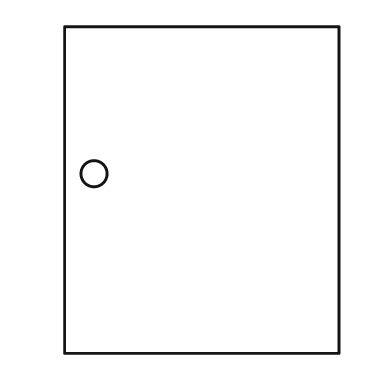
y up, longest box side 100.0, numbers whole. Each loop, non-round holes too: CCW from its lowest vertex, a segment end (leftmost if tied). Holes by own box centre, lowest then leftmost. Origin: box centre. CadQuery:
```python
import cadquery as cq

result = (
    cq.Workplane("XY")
    .moveTo(-42.0, -50.0)
    .lineTo(42.0, -50.0)
    .lineTo(42.0, 50.0)
    .lineTo(-42.0, 50.0)
    .close()
    .moveTo(-33.0, 5.0)
    .circle(4.0)
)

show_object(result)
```